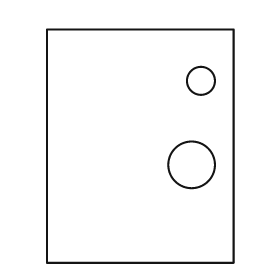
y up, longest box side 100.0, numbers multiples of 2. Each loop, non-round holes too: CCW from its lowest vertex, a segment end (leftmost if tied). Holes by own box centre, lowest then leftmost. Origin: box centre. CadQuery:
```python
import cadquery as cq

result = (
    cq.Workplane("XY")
    .moveTo(-40.0, -50.0)
    .lineTo(40.0, -50.0)
    .lineTo(40.0, 50.0)
    .lineTo(-40.0, 50.0)
    .close()
    .moveTo(22.0, -8.0)
    .circle(10.0)
    .moveTo(26.0, 28.0)
    .circle(6.0)
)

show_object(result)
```